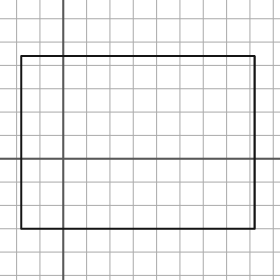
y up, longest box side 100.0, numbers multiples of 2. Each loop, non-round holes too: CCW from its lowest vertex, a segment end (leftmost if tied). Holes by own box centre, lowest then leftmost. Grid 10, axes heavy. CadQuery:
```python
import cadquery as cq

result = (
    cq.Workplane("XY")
    .moveTo(-18.0, -30.0)
    .lineTo(82.0, -30.0)
    .lineTo(82.0, 44.0)
    .lineTo(-18.0, 44.0)
    .close()
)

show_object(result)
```